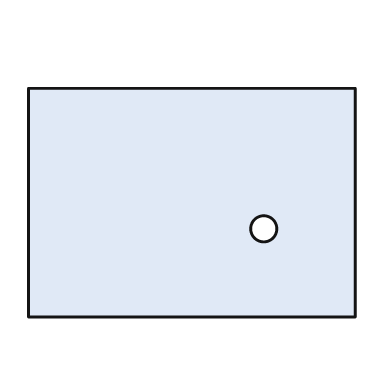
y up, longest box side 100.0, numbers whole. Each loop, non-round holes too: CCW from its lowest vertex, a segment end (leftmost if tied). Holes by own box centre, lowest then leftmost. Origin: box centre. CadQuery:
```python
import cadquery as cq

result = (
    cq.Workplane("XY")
    .moveTo(-50.0, -35.0)
    .lineTo(50.0, -35.0)
    .lineTo(50.0, 35.0)
    .lineTo(-50.0, 35.0)
    .close()
    .moveTo(22.0, -8.0)
    .circle(4.0)
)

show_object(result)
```